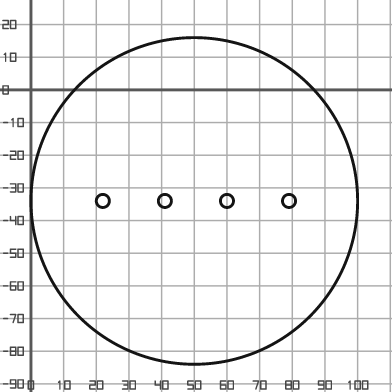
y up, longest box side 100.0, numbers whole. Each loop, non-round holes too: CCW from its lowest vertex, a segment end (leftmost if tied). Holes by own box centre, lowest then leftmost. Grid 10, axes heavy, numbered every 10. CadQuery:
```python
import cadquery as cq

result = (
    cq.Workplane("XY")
    .moveTo(50.0, -34.0)
    .circle(50.0)
    .moveTo(22.0, -34.0)
    .circle(2.0)
    .moveTo(41.0, -34.0)
    .circle(2.0)
    .moveTo(60.0, -34.0)
    .circle(2.0)
    .moveTo(79.0, -34.0)
    .circle(2.0)
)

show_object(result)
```